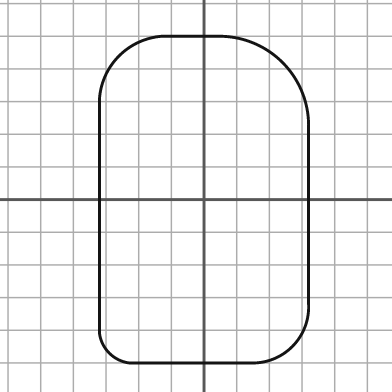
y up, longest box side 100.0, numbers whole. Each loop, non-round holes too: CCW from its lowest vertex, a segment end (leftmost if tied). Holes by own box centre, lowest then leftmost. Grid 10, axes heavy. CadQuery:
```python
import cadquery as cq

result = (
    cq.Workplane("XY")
    .moveTo(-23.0, -50.0)
    .lineTo(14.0, -50.0)
    .threePointArc((27.0, -45.0), (32.0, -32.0))
    .lineTo(32.0, 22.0)
    .threePointArc((24.0, 42.0), (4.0, 50.0))
    .lineTo(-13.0, 50.0)
    .threePointArc((-26.0, 44.0), (-32.0, 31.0))
    .lineTo(-32.0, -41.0)
    .threePointArc((-29.0, -47.0), (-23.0, -50.0))
    .close()
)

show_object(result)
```